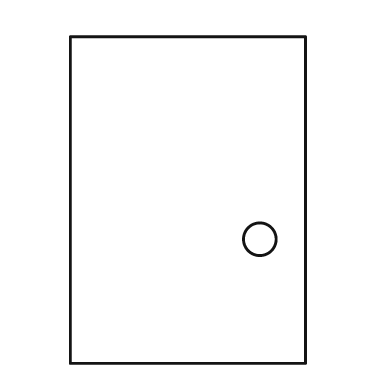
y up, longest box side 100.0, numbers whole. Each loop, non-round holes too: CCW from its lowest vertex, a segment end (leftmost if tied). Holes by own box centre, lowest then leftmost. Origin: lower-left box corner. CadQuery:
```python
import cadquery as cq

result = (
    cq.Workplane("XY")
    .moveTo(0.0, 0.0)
    .lineTo(72.0, 0.0)
    .lineTo(72.0, 100.0)
    .lineTo(0.0, 100.0)
    .close()
    .moveTo(58.0, 38.0)
    .circle(5.0)
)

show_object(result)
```